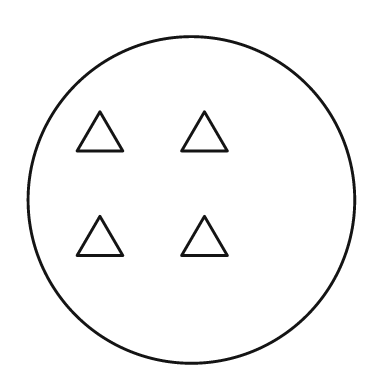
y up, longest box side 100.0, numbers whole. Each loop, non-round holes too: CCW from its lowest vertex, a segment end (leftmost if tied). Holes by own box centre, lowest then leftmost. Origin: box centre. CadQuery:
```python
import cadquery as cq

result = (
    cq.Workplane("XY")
    .moveTo(0.0, 0.0)
    .circle(50.0)
    .moveTo(-35.0, -17.0)
    .lineTo(-21.0, -17.0)
    .lineTo(-28.0, -5.0)
    .close()
    .moveTo(-3.0, -17.0)
    .lineTo(11.0, -17.0)
    .lineTo(4.0, -5.0)
    .close()
    .moveTo(-35.0, 15.0)
    .lineTo(-21.0, 15.0)
    .lineTo(-28.0, 27.0)
    .close()
    .moveTo(-3.0, 15.0)
    .lineTo(11.0, 15.0)
    .lineTo(4.0, 27.0)
    .close()
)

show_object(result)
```